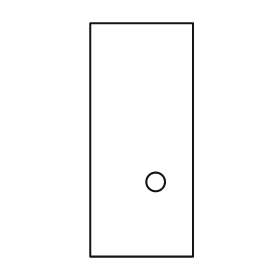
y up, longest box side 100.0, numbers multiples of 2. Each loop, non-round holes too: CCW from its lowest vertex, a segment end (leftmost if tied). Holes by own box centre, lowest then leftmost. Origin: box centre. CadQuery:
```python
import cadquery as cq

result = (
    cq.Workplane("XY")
    .moveTo(-22.0, -50.0)
    .lineTo(22.0, -50.0)
    .lineTo(22.0, 50.0)
    .lineTo(-22.0, 50.0)
    .close()
    .moveTo(6.0, -18.0)
    .circle(4.0)
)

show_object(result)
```